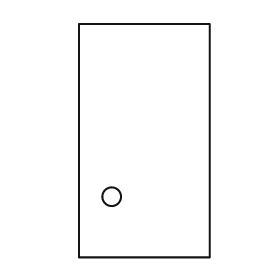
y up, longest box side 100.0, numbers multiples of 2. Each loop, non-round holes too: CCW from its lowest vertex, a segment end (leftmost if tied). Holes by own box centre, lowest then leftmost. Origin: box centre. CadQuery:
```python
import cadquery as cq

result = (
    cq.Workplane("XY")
    .moveTo(-28.0, -50.0)
    .lineTo(28.0, -50.0)
    .lineTo(28.0, 50.0)
    .lineTo(-28.0, 50.0)
    .close()
    .moveTo(-14.0, -24.0)
    .circle(4.0)
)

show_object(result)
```